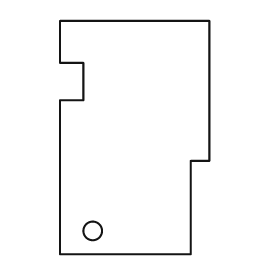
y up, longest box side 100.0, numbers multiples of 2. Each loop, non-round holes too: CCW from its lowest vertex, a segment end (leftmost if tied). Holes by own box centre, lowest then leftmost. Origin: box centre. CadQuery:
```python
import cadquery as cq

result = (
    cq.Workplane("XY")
    .moveTo(-32.0, -50.0)
    .lineTo(24.0, -50.0)
    .lineTo(24.0, -10.0)
    .lineTo(32.0, -10.0)
    .lineTo(32.0, 50.0)
    .lineTo(-32.0, 50.0)
    .lineTo(-32.0, 32.0)
    .lineTo(-22.0, 32.0)
    .lineTo(-22.0, 16.0)
    .lineTo(-32.0, 16.0)
    .close()
    .moveTo(-18.0, -40.0)
    .circle(4.0)
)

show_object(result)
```